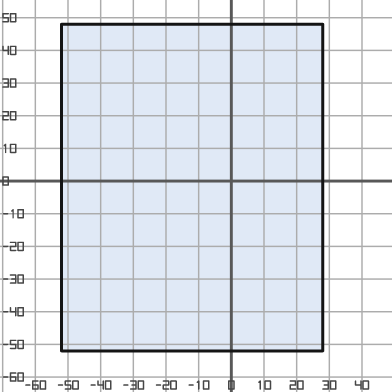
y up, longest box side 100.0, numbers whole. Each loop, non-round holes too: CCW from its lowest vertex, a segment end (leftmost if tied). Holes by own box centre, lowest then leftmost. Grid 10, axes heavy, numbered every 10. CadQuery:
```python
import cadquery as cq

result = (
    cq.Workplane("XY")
    .moveTo(-52.0, -52.0)
    .lineTo(28.0, -52.0)
    .lineTo(28.0, 48.0)
    .lineTo(-52.0, 48.0)
    .close()
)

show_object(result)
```